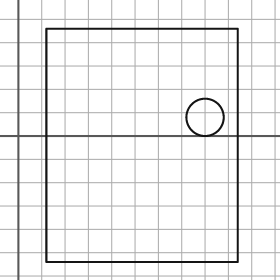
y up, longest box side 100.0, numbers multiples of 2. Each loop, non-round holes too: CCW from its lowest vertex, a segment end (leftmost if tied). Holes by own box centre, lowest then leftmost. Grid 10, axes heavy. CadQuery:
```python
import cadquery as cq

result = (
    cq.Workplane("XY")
    .moveTo(12.0, -54.0)
    .lineTo(94.0, -54.0)
    .lineTo(94.0, 46.0)
    .lineTo(12.0, 46.0)
    .close()
    .moveTo(80.0, 8.0)
    .circle(8.0)
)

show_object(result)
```